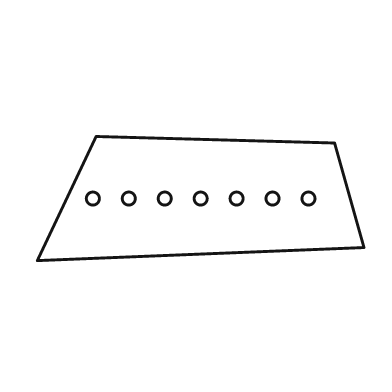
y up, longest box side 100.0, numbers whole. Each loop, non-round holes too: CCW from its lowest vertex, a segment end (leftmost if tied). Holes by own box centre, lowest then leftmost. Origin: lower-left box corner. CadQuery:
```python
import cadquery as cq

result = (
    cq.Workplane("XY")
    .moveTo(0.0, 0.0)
    .lineTo(100.0, 4.0)
    .lineTo(91.0, 36.0)
    .lineTo(18.0, 38.0)
    .close()
    .moveTo(17.0, 19.0)
    .circle(2.0)
    .moveTo(28.0, 19.0)
    .circle(2.0)
    .moveTo(39.0, 19.0)
    .circle(2.0)
    .moveTo(50.0, 19.0)
    .circle(2.0)
    .moveTo(61.0, 19.0)
    .circle(2.0)
    .moveTo(72.0, 19.0)
    .circle(2.0)
    .moveTo(83.0, 19.0)
    .circle(2.0)
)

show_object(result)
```